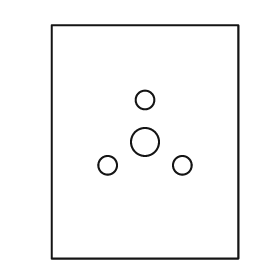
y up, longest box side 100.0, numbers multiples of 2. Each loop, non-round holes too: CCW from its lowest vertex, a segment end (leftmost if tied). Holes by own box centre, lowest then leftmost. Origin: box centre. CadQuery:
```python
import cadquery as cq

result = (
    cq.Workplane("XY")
    .moveTo(-40.0, -50.0)
    .lineTo(40.0, -50.0)
    .lineTo(40.0, 50.0)
    .lineTo(-40.0, 50.0)
    .close()
    .moveTo(-16.0, -10.0)
    .circle(4.0)
    .moveTo(16.0, -10.0)
    .circle(4.0)
    .moveTo(0.0, 0.0)
    .circle(6.0)
    .moveTo(0.0, 18.0)
    .circle(4.0)
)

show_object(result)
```